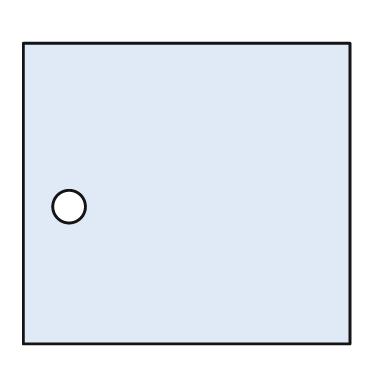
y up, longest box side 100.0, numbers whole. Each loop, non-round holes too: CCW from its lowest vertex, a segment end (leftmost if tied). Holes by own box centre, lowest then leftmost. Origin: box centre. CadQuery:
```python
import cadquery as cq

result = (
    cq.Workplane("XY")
    .moveTo(-50.0, -46.0)
    .lineTo(50.0, -46.0)
    .lineTo(50.0, 46.0)
    .lineTo(-50.0, 46.0)
    .close()
    .moveTo(-36.0, -4.0)
    .circle(5.0)
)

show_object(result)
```